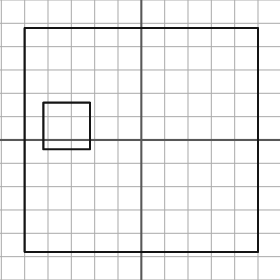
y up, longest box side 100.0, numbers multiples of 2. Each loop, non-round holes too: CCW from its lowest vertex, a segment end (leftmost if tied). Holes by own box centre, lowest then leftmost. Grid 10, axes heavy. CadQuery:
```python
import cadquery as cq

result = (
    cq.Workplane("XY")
    .moveTo(-50.0, -48.0)
    .lineTo(50.0, -48.0)
    .lineTo(50.0, 48.0)
    .lineTo(-50.0, 48.0)
    .close()
    .moveTo(-42.0, -4.0)
    .lineTo(-22.0, -4.0)
    .lineTo(-22.0, 16.0)
    .lineTo(-42.0, 16.0)
    .close()
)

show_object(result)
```